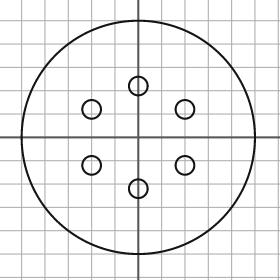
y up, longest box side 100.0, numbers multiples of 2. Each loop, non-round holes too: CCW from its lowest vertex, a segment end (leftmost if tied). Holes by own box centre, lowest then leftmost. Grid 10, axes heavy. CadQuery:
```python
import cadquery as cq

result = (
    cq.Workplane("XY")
    .moveTo(0.0, 0.0)
    .circle(50.0)
    .moveTo(0.0, -22.0)
    .circle(4.0)
    .moveTo(-20.0, -12.0)
    .circle(4.0)
    .moveTo(20.0, -12.0)
    .circle(4.0)
    .moveTo(-20.0, 12.0)
    .circle(4.0)
    .moveTo(20.0, 12.0)
    .circle(4.0)
    .moveTo(0.0, 22.0)
    .circle(4.0)
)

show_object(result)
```